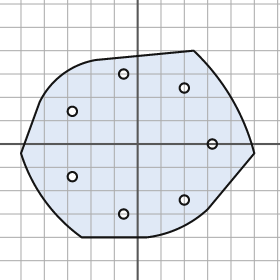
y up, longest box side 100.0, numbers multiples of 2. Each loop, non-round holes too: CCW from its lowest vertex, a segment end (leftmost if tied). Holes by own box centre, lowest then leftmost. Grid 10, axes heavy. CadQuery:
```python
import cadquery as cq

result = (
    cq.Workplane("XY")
    .moveTo(-24.0, -40.0)
    .lineTo(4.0, -40.0)
    .threePointArc((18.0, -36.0), (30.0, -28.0))
    .lineTo(50.0, -4.0)
    .threePointArc((40.0, 20.0), (24.0, 40.0))
    .lineTo(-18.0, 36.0)
    .threePointArc((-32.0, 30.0), (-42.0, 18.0))
    .lineTo(-50.0, -4.0)
    .threePointArc((-40.0, -24.0), (-24.0, -40.0))
    .close()
    .moveTo(-6.0, -30.0)
    .circle(2.0)
    .moveTo(20.0, -24.0)
    .circle(2.0)
    .moveTo(-28.0, -14.0)
    .circle(2.0)
    .moveTo(32.0, 0.0)
    .circle(2.0)
    .moveTo(-28.0, 14.0)
    .circle(2.0)
    .moveTo(20.0, 24.0)
    .circle(2.0)
    .moveTo(-6.0, 30.0)
    .circle(2.0)
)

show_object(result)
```